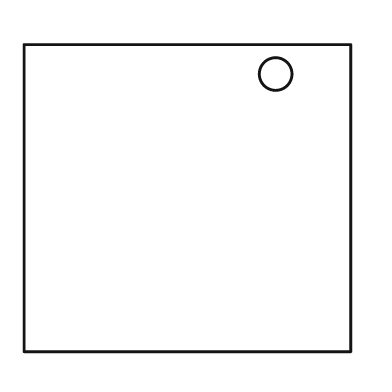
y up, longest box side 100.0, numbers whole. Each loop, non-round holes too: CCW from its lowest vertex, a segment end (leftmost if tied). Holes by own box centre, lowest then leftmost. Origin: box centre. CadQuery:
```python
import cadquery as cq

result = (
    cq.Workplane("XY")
    .moveTo(-50.0, -47.0)
    .lineTo(50.0, -47.0)
    .lineTo(50.0, 47.0)
    .lineTo(-50.0, 47.0)
    .close()
    .moveTo(27.0, 38.0)
    .circle(5.0)
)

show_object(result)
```